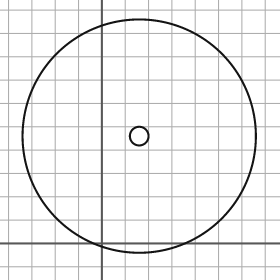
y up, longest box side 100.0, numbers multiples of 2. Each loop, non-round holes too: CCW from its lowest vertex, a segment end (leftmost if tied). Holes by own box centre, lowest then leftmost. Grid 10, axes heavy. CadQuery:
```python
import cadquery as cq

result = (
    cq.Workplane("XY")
    .moveTo(16.0, 46.0)
    .circle(50.0)
    .moveTo(16.0, 46.0)
    .circle(4.0)
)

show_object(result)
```